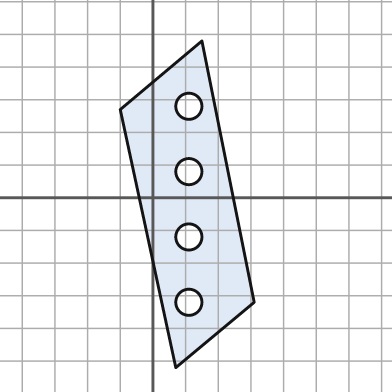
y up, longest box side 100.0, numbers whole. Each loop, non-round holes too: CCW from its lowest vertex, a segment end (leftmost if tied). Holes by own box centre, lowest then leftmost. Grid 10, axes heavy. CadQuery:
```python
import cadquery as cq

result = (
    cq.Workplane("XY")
    .moveTo(7.0, -52.0)
    .lineTo(31.0, -32.0)
    .lineTo(15.0, 48.0)
    .lineTo(-10.0, 27.0)
    .close()
    .moveTo(11.0, -32.0)
    .circle(4.0)
    .moveTo(11.0, -12.0)
    .circle(4.0)
    .moveTo(11.0, 8.0)
    .circle(4.0)
    .moveTo(11.0, 28.0)
    .circle(4.0)
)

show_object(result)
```